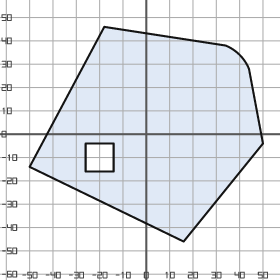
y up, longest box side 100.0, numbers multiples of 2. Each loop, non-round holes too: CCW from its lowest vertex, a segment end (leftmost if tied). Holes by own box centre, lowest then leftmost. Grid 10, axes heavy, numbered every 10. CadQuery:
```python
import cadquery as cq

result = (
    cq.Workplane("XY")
    .moveTo(16.0, -46.0)
    .lineTo(50.0, -4.0)
    .lineTo(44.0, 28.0)
    .threePointArc((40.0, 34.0), (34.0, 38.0))
    .lineTo(-18.0, 46.0)
    .lineTo(-50.0, -14.0)
    .close()
    .moveTo(-26.0, -16.0)
    .lineTo(-14.0, -16.0)
    .lineTo(-14.0, -4.0)
    .lineTo(-26.0, -4.0)
    .close()
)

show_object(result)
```